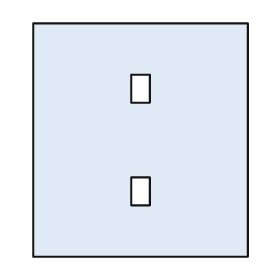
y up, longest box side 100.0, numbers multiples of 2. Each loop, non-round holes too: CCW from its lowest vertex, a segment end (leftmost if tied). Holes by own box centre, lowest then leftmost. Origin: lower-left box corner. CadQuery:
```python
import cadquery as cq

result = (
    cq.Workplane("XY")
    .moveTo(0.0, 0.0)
    .lineTo(92.0, 0.0)
    .lineTo(92.0, 100.0)
    .lineTo(0.0, 100.0)
    .close()
    .moveTo(42.0, 22.0)
    .lineTo(50.0, 22.0)
    .lineTo(50.0, 34.0)
    .lineTo(42.0, 34.0)
    .close()
    .moveTo(42.0, 66.0)
    .lineTo(50.0, 66.0)
    .lineTo(50.0, 78.0)
    .lineTo(42.0, 78.0)
    .close()
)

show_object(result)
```